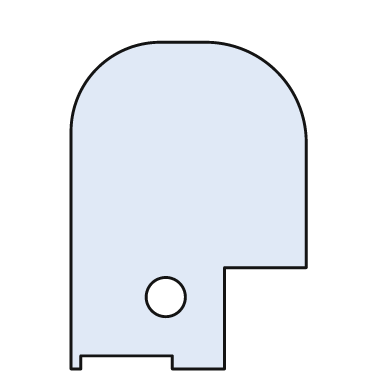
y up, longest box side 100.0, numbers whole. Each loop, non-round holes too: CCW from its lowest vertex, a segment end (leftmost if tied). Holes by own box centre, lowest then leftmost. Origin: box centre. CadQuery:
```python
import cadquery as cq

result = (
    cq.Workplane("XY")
    .moveTo(-36.0, -50.0)
    .lineTo(-33.0, -50.0)
    .lineTo(-33.0, -46.0)
    .lineTo(-5.0, -46.0)
    .lineTo(-5.0, -50.0)
    .lineTo(11.0, -50.0)
    .lineTo(11.0, -19.0)
    .lineTo(36.0, -19.0)
    .lineTo(36.0, 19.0)
    .threePointArc((27.0, 41.0), (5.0, 50.0))
    .lineTo(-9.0, 50.0)
    .threePointArc((-28.0, 42.0), (-36.0, 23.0))
    .close()
    .moveTo(-7.0, -28.0)
    .circle(6.0)
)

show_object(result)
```